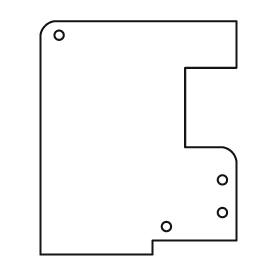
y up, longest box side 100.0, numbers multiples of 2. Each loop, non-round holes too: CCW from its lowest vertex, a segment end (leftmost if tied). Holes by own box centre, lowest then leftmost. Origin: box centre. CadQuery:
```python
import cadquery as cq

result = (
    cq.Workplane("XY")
    .moveTo(-42.0, -50.0)
    .lineTo(6.0, -50.0)
    .lineTo(6.0, -44.0)
    .lineTo(42.0, -44.0)
    .lineTo(42.0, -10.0)
    .threePointArc((40.0, -6.0), (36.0, -4.0))
    .lineTo(20.0, -4.0)
    .lineTo(20.0, 30.0)
    .lineTo(42.0, 30.0)
    .lineTo(42.0, 50.0)
    .lineTo(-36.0, 50.0)
    .threePointArc((-40.0, 48.0), (-42.0, 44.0))
    .close()
    .moveTo(12.0, -38.0)
    .circle(2.0)
    .moveTo(36.0, -32.0)
    .circle(2.0)
    .moveTo(36.0, -18.0)
    .circle(2.0)
    .moveTo(-34.0, 44.0)
    .circle(2.0)
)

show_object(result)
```